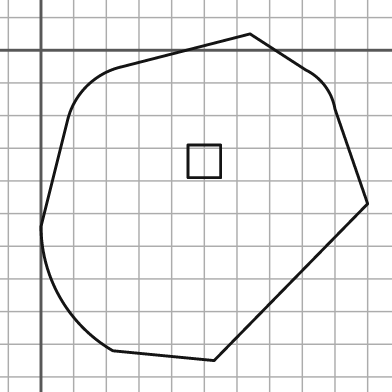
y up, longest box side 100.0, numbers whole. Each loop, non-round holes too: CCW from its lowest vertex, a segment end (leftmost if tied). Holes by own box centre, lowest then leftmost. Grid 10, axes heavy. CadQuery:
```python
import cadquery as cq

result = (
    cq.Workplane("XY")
    .moveTo(53.0, -95.0)
    .lineTo(100.0, -47.0)
    .lineTo(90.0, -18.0)
    .threePointArc((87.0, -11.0), (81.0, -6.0))
    .lineTo(64.0, 5.0)
    .lineTo(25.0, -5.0)
    .threePointArc((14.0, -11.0), (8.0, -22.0))
    .lineTo(0.0, -54.0)
    .threePointArc((6.0, -76.0), (22.0, -92.0))
    .close()
    .moveTo(45.0, -39.0)
    .lineTo(55.0, -39.0)
    .lineTo(55.0, -29.0)
    .lineTo(45.0, -29.0)
    .close()
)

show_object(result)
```